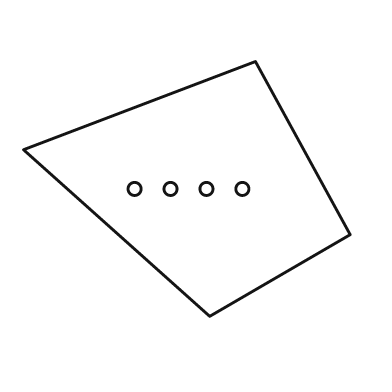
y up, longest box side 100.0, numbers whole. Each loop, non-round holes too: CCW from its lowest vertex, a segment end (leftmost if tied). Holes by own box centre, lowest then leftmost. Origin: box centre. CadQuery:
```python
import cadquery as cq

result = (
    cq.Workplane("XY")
    .moveTo(7.0, -39.0)
    .lineTo(50.0, -14.0)
    .lineTo(21.0, 39.0)
    .lineTo(-50.0, 12.0)
    .close()
    .moveTo(-16.0, 0.0)
    .circle(2.0)
    .moveTo(-5.0, 0.0)
    .circle(2.0)
    .moveTo(6.0, 0.0)
    .circle(2.0)
    .moveTo(17.0, 0.0)
    .circle(2.0)
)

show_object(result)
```